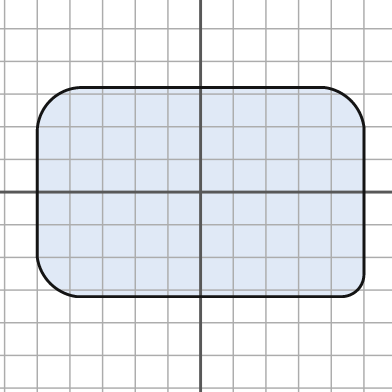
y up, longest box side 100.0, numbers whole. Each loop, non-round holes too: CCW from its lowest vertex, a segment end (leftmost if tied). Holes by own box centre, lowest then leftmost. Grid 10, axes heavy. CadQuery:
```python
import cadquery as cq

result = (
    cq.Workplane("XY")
    .moveTo(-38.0, -32.0)
    .lineTo(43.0, -32.0)
    .threePointArc((48.0, -30.0), (50.0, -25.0))
    .lineTo(50.0, 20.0)
    .threePointArc((46.0, 28.0), (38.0, 32.0))
    .lineTo(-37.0, 32.0)
    .threePointArc((-46.0, 28.0), (-50.0, 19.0))
    .lineTo(-50.0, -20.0)
    .threePointArc((-46.0, -28.0), (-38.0, -32.0))
    .close()
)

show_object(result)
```